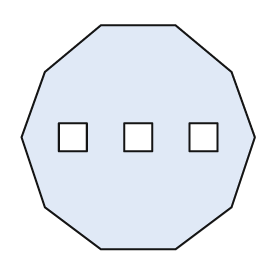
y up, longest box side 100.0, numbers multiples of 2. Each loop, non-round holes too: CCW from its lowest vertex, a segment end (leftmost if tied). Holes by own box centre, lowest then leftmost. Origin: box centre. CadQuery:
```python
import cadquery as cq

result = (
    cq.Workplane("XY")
    .moveTo(-16.0, -48.0)
    .lineTo(16.0, -48.0)
    .lineTo(40.0, -30.0)
    .lineTo(50.0, 0.0)
    .lineTo(40.0, 28.0)
    .lineTo(16.0, 48.0)
    .lineTo(-16.0, 48.0)
    .lineTo(-40.0, 28.0)
    .lineTo(-50.0, 0.0)
    .lineTo(-40.0, -30.0)
    .close()
    .moveTo(-34.0, -6.0)
    .lineTo(-22.0, -6.0)
    .lineTo(-22.0, 6.0)
    .lineTo(-34.0, 6.0)
    .close()
    .moveTo(-6.0, -6.0)
    .lineTo(6.0, -6.0)
    .lineTo(6.0, 6.0)
    .lineTo(-6.0, 6.0)
    .close()
    .moveTo(22.0, -6.0)
    .lineTo(34.0, -6.0)
    .lineTo(34.0, 6.0)
    .lineTo(22.0, 6.0)
    .close()
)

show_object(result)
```